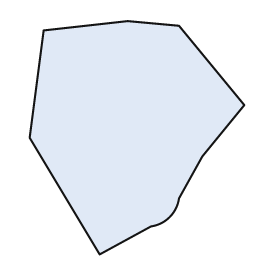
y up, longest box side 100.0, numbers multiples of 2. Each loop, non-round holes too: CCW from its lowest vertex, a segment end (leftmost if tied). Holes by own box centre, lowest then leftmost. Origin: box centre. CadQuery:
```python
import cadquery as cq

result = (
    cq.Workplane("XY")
    .moveTo(-16.0, -50.0)
    .lineTo(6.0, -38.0)
    .threePointArc((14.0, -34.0), (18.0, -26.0))
    .lineTo(28.0, -8.0)
    .lineTo(46.0, 14.0)
    .lineTo(18.0, 48.0)
    .lineTo(-4.0, 50.0)
    .lineTo(-40.0, 46.0)
    .lineTo(-46.0, 0.0)
    .close()
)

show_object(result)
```